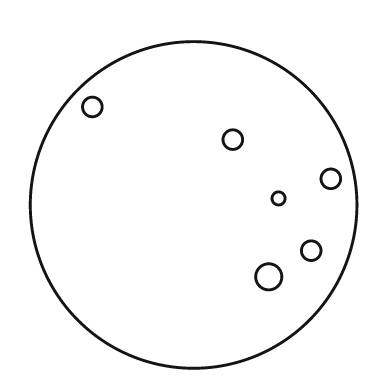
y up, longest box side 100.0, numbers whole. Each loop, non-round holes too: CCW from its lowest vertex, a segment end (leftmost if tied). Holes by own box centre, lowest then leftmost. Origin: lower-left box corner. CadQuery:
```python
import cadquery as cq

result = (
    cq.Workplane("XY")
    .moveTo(50.0, 50.0)
    .circle(50.0)
    .moveTo(73.0, 28.0)
    .circle(4.0)
    .moveTo(86.0, 36.0)
    .circle(3.0)
    .moveTo(76.0, 52.0)
    .circle(2.0)
    .moveTo(92.0, 58.0)
    .circle(3.0)
    .moveTo(62.0, 70.0)
    .circle(3.0)
    .moveTo(19.0, 80.0)
    .circle(3.0)
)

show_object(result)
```